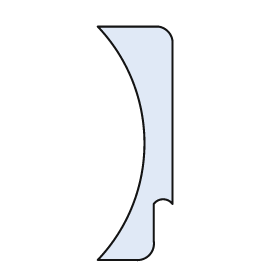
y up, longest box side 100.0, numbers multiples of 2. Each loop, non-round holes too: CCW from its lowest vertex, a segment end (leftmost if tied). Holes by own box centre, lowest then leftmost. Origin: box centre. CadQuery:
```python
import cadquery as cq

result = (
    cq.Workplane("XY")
    .moveTo(-16.0, -50.0)
    .lineTo(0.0, -50.0)
    .threePointArc((6.0, -48.0), (8.0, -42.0))
    .lineTo(8.0, -26.0)
    .threePointArc((12.0, -24.0), (16.0, -26.0))
    .lineTo(16.0, 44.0)
    .threePointArc((14.0, 48.0), (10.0, 50.0))
    .lineTo(-16.0, 50.0)
    .threePointArc((4.0, 0.0), (-16.0, -50.0))
    .close()
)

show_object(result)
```